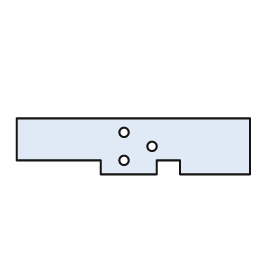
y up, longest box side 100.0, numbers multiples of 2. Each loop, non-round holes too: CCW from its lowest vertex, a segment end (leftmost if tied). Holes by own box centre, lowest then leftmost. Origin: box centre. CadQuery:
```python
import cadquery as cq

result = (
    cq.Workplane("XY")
    .moveTo(-14.0, -12.0)
    .lineTo(10.0, -12.0)
    .lineTo(10.0, -6.0)
    .lineTo(20.0, -6.0)
    .lineTo(20.0, -12.0)
    .lineTo(50.0, -12.0)
    .lineTo(50.0, 12.0)
    .lineTo(-50.0, 12.0)
    .lineTo(-50.0, -6.0)
    .lineTo(-14.0, -6.0)
    .close()
    .moveTo(-4.0, -6.0)
    .circle(2.0)
    .moveTo(8.0, 0.0)
    .circle(2.0)
    .moveTo(-4.0, 6.0)
    .circle(2.0)
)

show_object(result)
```